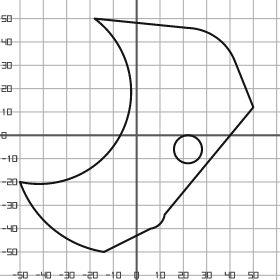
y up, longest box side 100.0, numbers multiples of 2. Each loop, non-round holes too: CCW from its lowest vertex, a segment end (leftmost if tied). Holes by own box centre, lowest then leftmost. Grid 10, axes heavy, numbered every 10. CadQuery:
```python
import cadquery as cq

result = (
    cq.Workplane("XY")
    .moveTo(-14.0, -50.0)
    .lineTo(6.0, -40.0)
    .threePointArc((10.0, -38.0), (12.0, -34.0))
    .lineTo(50.0, 12.0)
    .lineTo(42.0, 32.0)
    .threePointArc((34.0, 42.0), (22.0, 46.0))
    .lineTo(-18.0, 50.0)
    .threePointArc((-6.0, 2.0), (-50.0, -20.0))
    .threePointArc((-36.0, -40.0), (-14.0, -50.0))
    .close()
    .moveTo(22.0, -6.0)
    .circle(6.0)
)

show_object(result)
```